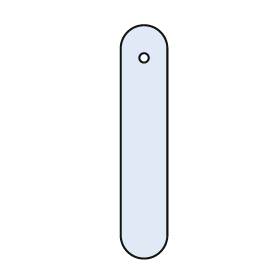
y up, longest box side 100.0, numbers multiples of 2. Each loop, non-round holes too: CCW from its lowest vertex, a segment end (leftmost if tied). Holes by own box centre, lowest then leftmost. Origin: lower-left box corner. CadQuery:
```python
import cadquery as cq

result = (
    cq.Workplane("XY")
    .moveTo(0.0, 10.0)
    .threePointArc((10.0, 0.0), (20.0, 10.0))
    .lineTo(20.0, 90.0)
    .threePointArc((10.0, 100.0), (0.0, 90.0))
    .close()
    .moveTo(10.0, 86.0)
    .circle(2.0)
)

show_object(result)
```